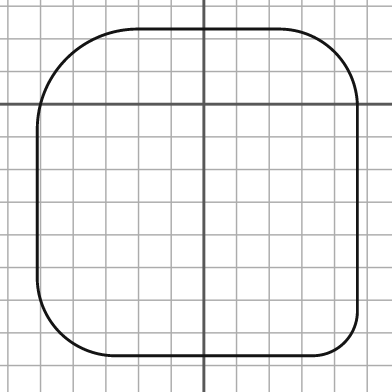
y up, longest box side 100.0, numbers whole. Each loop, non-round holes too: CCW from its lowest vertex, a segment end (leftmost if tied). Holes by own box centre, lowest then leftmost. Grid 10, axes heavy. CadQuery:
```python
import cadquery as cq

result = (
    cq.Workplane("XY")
    .moveTo(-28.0, -77.0)
    .lineTo(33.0, -77.0)
    .threePointArc((43.0, -73.0), (47.0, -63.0))
    .lineTo(47.0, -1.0)
    .threePointArc((40.0, 16.0), (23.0, 23.0))
    .lineTo(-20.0, 23.0)
    .threePointArc((-42.0, 14.0), (-51.0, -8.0))
    .lineTo(-51.0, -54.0)
    .threePointArc((-44.0, -70.0), (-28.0, -77.0))
    .close()
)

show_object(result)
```